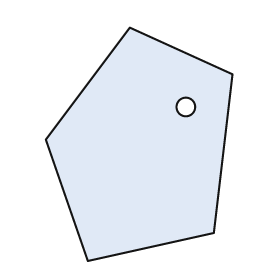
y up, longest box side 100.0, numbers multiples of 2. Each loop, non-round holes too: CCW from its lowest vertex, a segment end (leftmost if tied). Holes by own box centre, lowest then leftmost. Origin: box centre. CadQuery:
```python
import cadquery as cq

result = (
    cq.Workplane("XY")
    .moveTo(-22.0, -50.0)
    .lineTo(32.0, -38.0)
    .lineTo(40.0, 30.0)
    .lineTo(-4.0, 50.0)
    .lineTo(-40.0, 2.0)
    .close()
    .moveTo(20.0, 16.0)
    .circle(4.0)
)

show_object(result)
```